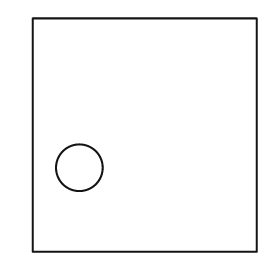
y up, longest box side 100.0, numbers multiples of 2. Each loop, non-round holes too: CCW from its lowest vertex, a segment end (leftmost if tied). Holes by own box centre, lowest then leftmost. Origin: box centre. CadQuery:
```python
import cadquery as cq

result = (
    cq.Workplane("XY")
    .moveTo(-48.0, -50.0)
    .lineTo(48.0, -50.0)
    .lineTo(48.0, 50.0)
    .lineTo(-48.0, 50.0)
    .close()
    .moveTo(-28.0, -14.0)
    .circle(10.0)
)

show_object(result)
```